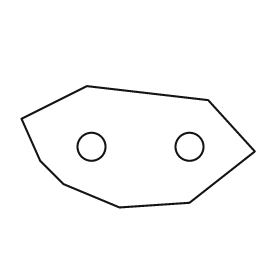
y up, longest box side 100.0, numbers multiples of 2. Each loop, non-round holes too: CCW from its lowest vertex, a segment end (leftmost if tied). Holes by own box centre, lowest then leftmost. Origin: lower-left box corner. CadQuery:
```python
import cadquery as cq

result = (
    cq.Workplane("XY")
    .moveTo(42.0, 0.0)
    .lineTo(72.0, 2.0)
    .lineTo(100.0, 24.0)
    .lineTo(80.0, 46.0)
    .lineTo(28.0, 52.0)
    .lineTo(0.0, 38.0)
    .lineTo(8.0, 20.0)
    .lineTo(18.0, 10.0)
    .close()
    .moveTo(30.0, 26.0)
    .circle(6.0)
    .moveTo(72.0, 26.0)
    .circle(6.0)
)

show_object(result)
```